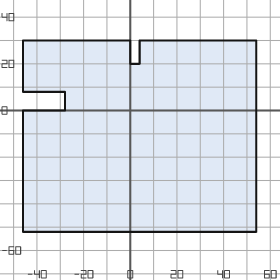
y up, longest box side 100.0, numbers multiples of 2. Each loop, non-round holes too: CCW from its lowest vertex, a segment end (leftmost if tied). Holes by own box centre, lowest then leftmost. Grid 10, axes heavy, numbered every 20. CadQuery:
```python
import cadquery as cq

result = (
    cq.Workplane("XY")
    .moveTo(-46.0, -52.0)
    .lineTo(54.0, -52.0)
    .lineTo(54.0, 30.0)
    .lineTo(4.0, 30.0)
    .lineTo(4.0, 20.0)
    .lineTo(0.0, 20.0)
    .lineTo(0.0, 30.0)
    .lineTo(-46.0, 30.0)
    .lineTo(-46.0, 8.0)
    .lineTo(-28.0, 8.0)
    .lineTo(-28.0, 0.0)
    .lineTo(-46.0, 0.0)
    .close()
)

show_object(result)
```